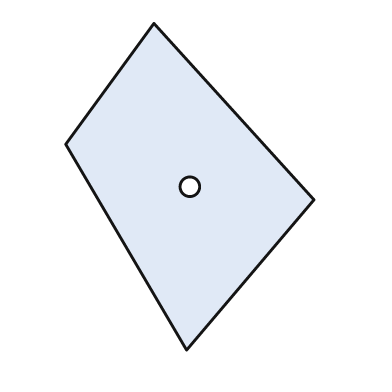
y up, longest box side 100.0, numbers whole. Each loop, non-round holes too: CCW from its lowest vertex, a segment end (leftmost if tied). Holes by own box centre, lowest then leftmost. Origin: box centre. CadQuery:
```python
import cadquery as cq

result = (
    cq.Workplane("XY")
    .moveTo(-1.0, -50.0)
    .lineTo(38.0, -4.0)
    .lineTo(-11.0, 50.0)
    .lineTo(-38.0, 13.0)
    .close()
    .moveTo(0.0, 0.0)
    .circle(3.0)
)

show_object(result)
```